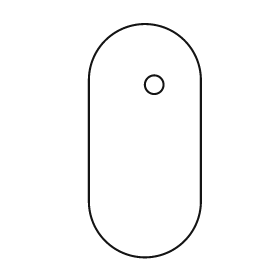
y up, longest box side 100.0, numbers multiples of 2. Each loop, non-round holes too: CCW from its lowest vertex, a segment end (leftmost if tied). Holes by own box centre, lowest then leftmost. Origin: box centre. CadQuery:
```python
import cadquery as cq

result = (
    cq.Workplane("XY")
    .moveTo(-24.0, -26.0)
    .threePointArc((0.0, -50.0), (24.0, -26.0))
    .lineTo(24.0, 26.0)
    .threePointArc((0.0, 50.0), (-24.0, 26.0))
    .close()
    .moveTo(4.0, 24.0)
    .circle(4.0)
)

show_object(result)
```